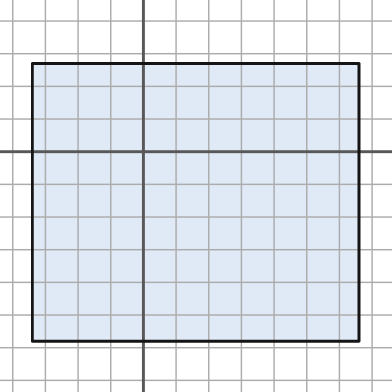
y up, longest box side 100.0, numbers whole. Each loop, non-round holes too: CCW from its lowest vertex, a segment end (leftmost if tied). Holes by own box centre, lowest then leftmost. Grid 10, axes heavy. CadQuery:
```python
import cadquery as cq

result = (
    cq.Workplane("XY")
    .moveTo(-34.0, -58.0)
    .lineTo(66.0, -58.0)
    .lineTo(66.0, 27.0)
    .lineTo(-34.0, 27.0)
    .close()
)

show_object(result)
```